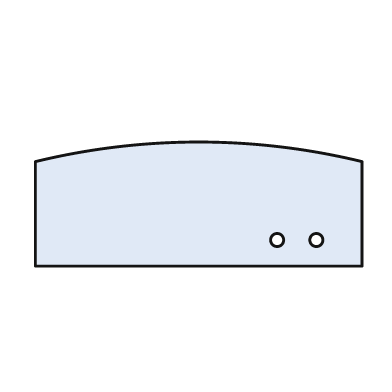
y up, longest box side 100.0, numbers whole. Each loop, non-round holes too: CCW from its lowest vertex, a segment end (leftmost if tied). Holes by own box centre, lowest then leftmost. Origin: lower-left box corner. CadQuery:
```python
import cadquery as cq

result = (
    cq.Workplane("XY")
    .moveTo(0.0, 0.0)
    .lineTo(100.0, 0.0)
    .lineTo(100.0, 32.0)
    .threePointArc((50.0, 38.0), (0.0, 32.0))
    .close()
    .moveTo(74.0, 8.0)
    .circle(2.0)
    .moveTo(86.0, 8.0)
    .circle(2.0)
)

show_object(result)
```